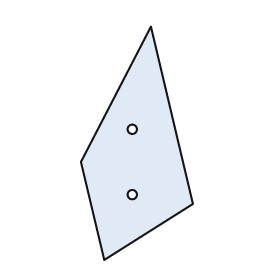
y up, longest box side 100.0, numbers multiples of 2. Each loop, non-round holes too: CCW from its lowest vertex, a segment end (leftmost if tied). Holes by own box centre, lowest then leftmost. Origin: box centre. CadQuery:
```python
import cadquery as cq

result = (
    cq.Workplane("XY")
    .moveTo(-14.0, -50.0)
    .lineTo(24.0, -26.0)
    .lineTo(6.0, 50.0)
    .lineTo(-24.0, -8.0)
    .close()
    .moveTo(-2.0, -22.0)
    .circle(2.0)
    .moveTo(-2.0, 6.0)
    .circle(2.0)
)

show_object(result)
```